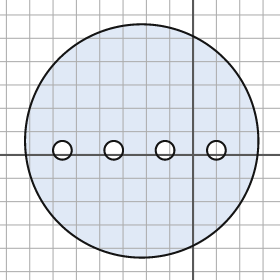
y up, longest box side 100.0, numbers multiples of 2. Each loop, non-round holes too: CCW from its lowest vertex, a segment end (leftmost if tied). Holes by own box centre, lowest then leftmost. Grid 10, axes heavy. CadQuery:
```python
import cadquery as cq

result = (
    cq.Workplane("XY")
    .moveTo(-22.0, 6.0)
    .circle(50.0)
    .moveTo(-56.0, 2.0)
    .circle(4.0)
    .moveTo(-34.0, 2.0)
    .circle(4.0)
    .moveTo(-12.0, 2.0)
    .circle(4.0)
    .moveTo(10.0, 2.0)
    .circle(4.0)
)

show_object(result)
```